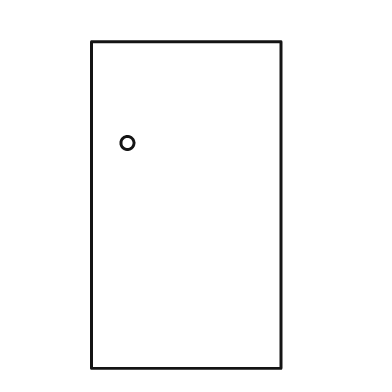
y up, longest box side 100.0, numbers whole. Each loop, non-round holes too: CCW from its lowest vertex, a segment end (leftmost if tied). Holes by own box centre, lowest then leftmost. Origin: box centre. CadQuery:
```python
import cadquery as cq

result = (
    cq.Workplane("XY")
    .moveTo(-29.0, -50.0)
    .lineTo(29.0, -50.0)
    .lineTo(29.0, 50.0)
    .lineTo(-29.0, 50.0)
    .close()
    .moveTo(-18.0, 19.0)
    .circle(2.0)
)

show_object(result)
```